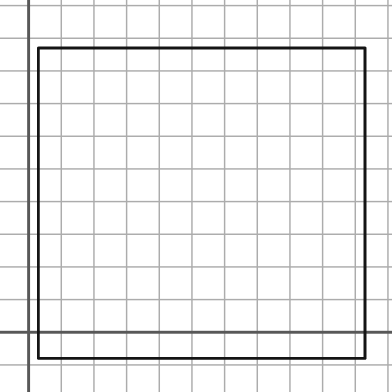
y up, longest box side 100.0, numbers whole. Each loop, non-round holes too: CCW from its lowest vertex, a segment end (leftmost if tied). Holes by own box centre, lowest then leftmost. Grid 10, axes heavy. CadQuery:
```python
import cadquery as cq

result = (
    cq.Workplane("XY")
    .moveTo(3.0, -8.0)
    .lineTo(103.0, -8.0)
    .lineTo(103.0, 87.0)
    .lineTo(3.0, 87.0)
    .close()
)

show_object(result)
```